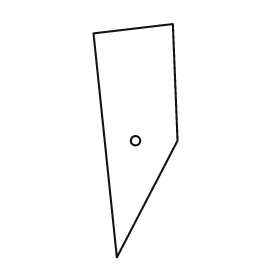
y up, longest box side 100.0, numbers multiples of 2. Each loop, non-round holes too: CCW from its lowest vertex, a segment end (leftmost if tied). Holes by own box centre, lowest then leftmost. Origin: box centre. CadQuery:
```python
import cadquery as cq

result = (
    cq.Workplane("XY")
    .moveTo(-8.0, -50.0)
    .lineTo(18.0, 0.0)
    .lineTo(16.0, 50.0)
    .lineTo(-18.0, 46.0)
    .close()
    .moveTo(0.0, 0.0)
    .circle(2.0)
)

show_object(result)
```